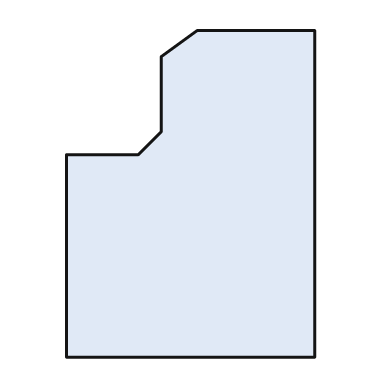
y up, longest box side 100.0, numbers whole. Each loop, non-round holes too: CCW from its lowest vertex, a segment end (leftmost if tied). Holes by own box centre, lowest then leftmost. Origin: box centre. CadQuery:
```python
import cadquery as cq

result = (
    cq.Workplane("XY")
    .moveTo(-38.0, -50.0)
    .lineTo(38.0, -50.0)
    .lineTo(38.0, 50.0)
    .lineTo(2.0, 50.0)
    .lineTo(-9.0, 42.0)
    .lineTo(-9.0, 19.0)
    .lineTo(-16.0, 12.0)
    .lineTo(-38.0, 12.0)
    .close()
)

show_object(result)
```